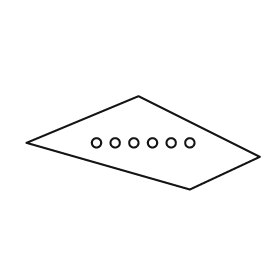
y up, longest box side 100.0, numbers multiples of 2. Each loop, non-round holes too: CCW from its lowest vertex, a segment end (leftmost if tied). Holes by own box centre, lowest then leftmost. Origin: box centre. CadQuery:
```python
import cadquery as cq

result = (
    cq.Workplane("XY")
    .moveTo(20.0, -20.0)
    .lineTo(50.0, -6.0)
    .lineTo(-2.0, 20.0)
    .lineTo(-50.0, 0.0)
    .close()
    .moveTo(-20.0, 0.0)
    .circle(2.0)
    .moveTo(-12.0, 0.0)
    .circle(2.0)
    .moveTo(-4.0, 0.0)
    .circle(2.0)
    .moveTo(4.0, 0.0)
    .circle(2.0)
    .moveTo(12.0, 0.0)
    .circle(2.0)
    .moveTo(20.0, 0.0)
    .circle(2.0)
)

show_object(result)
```